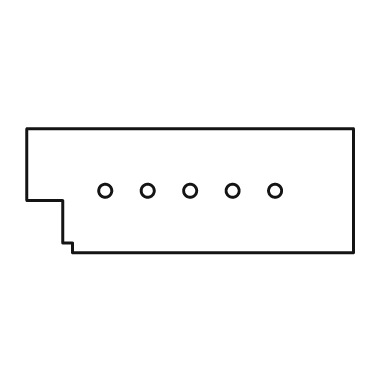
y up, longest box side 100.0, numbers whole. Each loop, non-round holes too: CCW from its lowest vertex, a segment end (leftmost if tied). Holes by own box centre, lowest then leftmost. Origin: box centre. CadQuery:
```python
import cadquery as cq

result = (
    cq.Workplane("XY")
    .moveTo(-36.0, -19.0)
    .lineTo(50.0, -19.0)
    .lineTo(50.0, 19.0)
    .lineTo(-50.0, 19.0)
    .lineTo(-50.0, -3.0)
    .lineTo(-39.0, -3.0)
    .lineTo(-39.0, -16.0)
    .lineTo(-36.0, -16.0)
    .close()
    .moveTo(-26.0, 0.0)
    .circle(2.0)
    .moveTo(-13.0, 0.0)
    .circle(2.0)
    .moveTo(0.0, 0.0)
    .circle(2.0)
    .moveTo(13.0, 0.0)
    .circle(2.0)
    .moveTo(26.0, 0.0)
    .circle(2.0)
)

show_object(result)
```